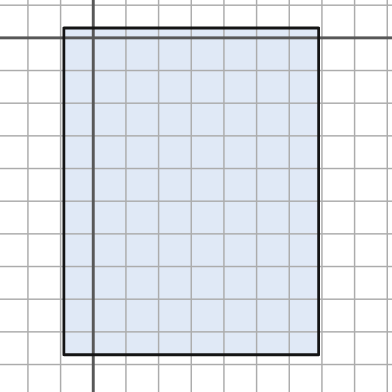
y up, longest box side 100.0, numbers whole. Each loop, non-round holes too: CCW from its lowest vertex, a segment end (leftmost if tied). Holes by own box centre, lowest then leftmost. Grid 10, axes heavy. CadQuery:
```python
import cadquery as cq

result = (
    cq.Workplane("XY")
    .moveTo(-9.0, -97.0)
    .lineTo(69.0, -97.0)
    .lineTo(69.0, 3.0)
    .lineTo(-9.0, 3.0)
    .close()
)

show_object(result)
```